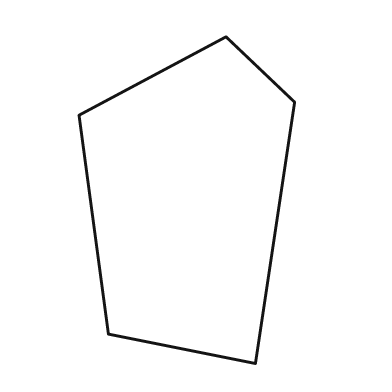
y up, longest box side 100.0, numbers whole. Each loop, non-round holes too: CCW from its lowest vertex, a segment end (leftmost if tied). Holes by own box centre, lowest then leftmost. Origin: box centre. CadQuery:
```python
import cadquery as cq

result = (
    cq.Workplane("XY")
    .moveTo(21.0, -50.0)
    .lineTo(33.0, 30.0)
    .lineTo(12.0, 50.0)
    .lineTo(-33.0, 26.0)
    .lineTo(-24.0, -41.0)
    .close()
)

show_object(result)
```